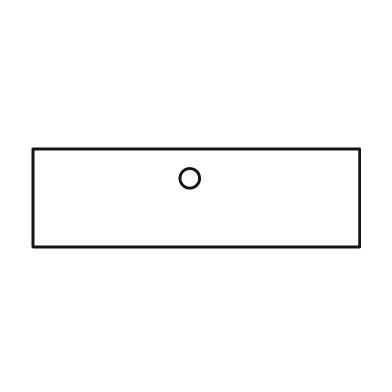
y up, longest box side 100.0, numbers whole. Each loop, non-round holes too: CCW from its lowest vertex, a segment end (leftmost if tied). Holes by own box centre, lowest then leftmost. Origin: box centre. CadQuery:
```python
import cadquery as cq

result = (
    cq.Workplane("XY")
    .moveTo(-50.0, -15.0)
    .lineTo(50.0, -15.0)
    .lineTo(50.0, 15.0)
    .lineTo(-50.0, 15.0)
    .close()
    .moveTo(-2.0, 6.0)
    .circle(3.0)
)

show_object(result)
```